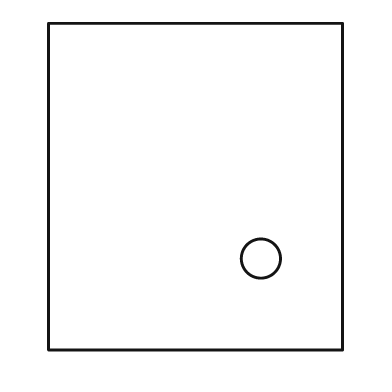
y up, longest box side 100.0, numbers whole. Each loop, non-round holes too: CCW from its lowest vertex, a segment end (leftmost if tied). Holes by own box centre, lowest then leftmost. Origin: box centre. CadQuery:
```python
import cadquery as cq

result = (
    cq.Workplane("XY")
    .moveTo(-45.0, -50.0)
    .lineTo(45.0, -50.0)
    .lineTo(45.0, 50.0)
    .lineTo(-45.0, 50.0)
    .close()
    .moveTo(20.0, -22.0)
    .circle(6.0)
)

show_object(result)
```